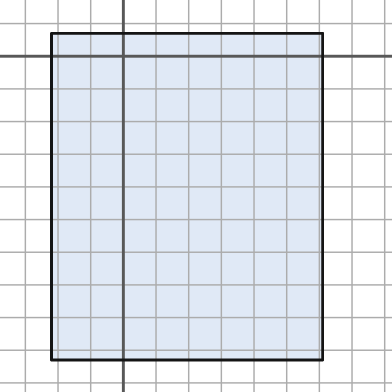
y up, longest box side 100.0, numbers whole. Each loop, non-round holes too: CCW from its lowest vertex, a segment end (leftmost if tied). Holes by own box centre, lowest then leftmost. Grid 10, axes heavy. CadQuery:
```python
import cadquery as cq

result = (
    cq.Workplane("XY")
    .moveTo(-22.0, -93.0)
    .lineTo(61.0, -93.0)
    .lineTo(61.0, 7.0)
    .lineTo(-22.0, 7.0)
    .close()
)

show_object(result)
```